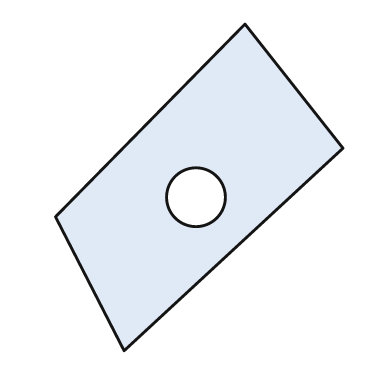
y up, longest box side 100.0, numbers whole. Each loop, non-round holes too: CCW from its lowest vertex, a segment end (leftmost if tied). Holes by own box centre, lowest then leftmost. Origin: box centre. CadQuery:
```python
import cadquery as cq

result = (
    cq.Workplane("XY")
    .moveTo(-23.0, -50.0)
    .lineTo(44.0, 12.0)
    .lineTo(14.0, 50.0)
    .lineTo(-44.0, -9.0)
    .close()
    .moveTo(-1.0, -3.0)
    .circle(9.0)
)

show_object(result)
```